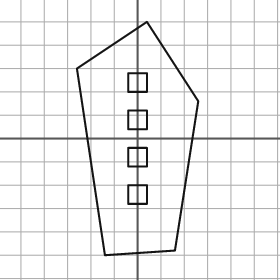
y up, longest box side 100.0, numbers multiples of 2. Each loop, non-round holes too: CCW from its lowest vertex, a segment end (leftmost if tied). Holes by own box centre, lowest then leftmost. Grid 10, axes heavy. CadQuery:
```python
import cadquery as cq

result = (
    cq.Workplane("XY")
    .moveTo(-14.0, -50.0)
    .lineTo(16.0, -48.0)
    .lineTo(26.0, 16.0)
    .lineTo(4.0, 50.0)
    .lineTo(-26.0, 30.0)
    .close()
    .moveTo(-4.0, -28.0)
    .lineTo(4.0, -28.0)
    .lineTo(4.0, -20.0)
    .lineTo(-4.0, -20.0)
    .close()
    .moveTo(-4.0, -12.0)
    .lineTo(4.0, -12.0)
    .lineTo(4.0, -4.0)
    .lineTo(-4.0, -4.0)
    .close()
    .moveTo(-4.0, 4.0)
    .lineTo(4.0, 4.0)
    .lineTo(4.0, 12.0)
    .lineTo(-4.0, 12.0)
    .close()
    .moveTo(-4.0, 20.0)
    .lineTo(4.0, 20.0)
    .lineTo(4.0, 28.0)
    .lineTo(-4.0, 28.0)
    .close()
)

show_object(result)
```